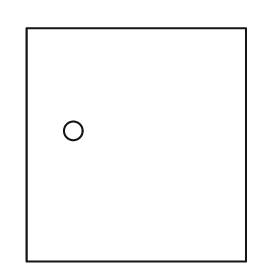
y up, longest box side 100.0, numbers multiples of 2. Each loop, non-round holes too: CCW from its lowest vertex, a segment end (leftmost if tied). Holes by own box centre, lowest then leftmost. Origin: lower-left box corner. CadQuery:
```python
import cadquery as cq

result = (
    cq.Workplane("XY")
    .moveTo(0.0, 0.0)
    .lineTo(94.0, 0.0)
    .lineTo(94.0, 100.0)
    .lineTo(0.0, 100.0)
    .close()
    .moveTo(20.0, 56.0)
    .circle(4.0)
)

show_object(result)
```